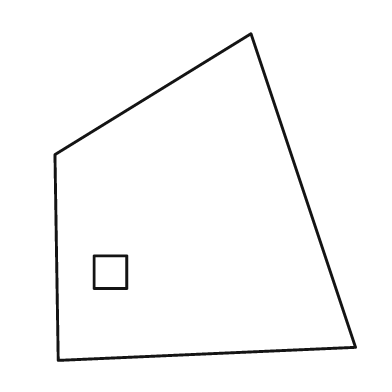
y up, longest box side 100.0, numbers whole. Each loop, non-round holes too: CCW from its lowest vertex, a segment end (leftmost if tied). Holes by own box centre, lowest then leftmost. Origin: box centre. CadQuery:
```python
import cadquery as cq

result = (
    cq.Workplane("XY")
    .moveTo(-45.0, -50.0)
    .lineTo(46.0, -46.0)
    .lineTo(14.0, 50.0)
    .lineTo(-46.0, 13.0)
    .close()
    .moveTo(-34.0, -28.0)
    .lineTo(-24.0, -28.0)
    .lineTo(-24.0, -18.0)
    .lineTo(-34.0, -18.0)
    .close()
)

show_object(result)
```